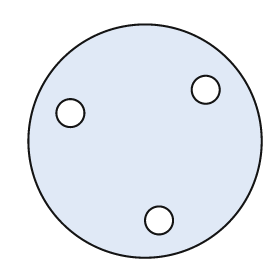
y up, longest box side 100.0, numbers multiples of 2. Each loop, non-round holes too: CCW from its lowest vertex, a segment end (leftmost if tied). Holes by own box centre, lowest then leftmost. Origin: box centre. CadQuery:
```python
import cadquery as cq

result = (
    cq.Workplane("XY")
    .moveTo(0.0, 0.0)
    .circle(50.0)
    .moveTo(6.0, -34.0)
    .circle(6.0)
    .moveTo(-32.0, 12.0)
    .circle(6.0)
    .moveTo(26.0, 22.0)
    .circle(6.0)
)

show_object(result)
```